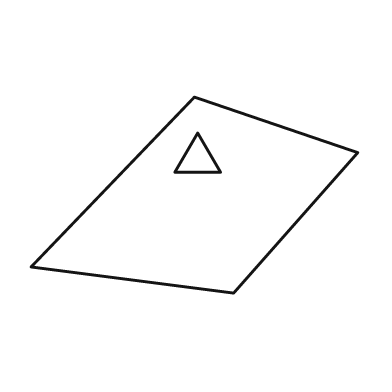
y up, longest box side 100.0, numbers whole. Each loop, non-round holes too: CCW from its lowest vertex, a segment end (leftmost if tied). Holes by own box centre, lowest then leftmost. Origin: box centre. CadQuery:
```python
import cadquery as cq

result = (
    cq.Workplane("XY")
    .moveTo(12.0, -30.0)
    .lineTo(50.0, 13.0)
    .lineTo(0.0, 30.0)
    .lineTo(-50.0, -22.0)
    .close()
    .moveTo(-6.0, 7.0)
    .lineTo(8.0, 7.0)
    .lineTo(1.0, 19.0)
    .close()
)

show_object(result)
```